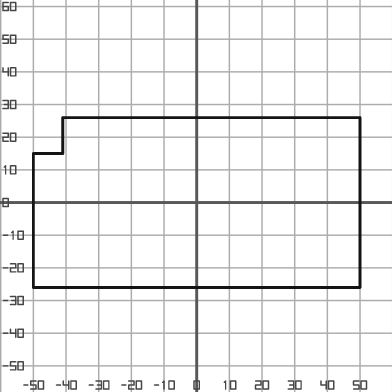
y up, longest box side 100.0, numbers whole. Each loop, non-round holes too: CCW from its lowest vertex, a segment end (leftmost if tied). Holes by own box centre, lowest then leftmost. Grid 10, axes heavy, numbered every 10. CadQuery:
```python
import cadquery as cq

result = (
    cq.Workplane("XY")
    .moveTo(-50.0, -26.0)
    .lineTo(50.0, -26.0)
    .lineTo(50.0, 26.0)
    .lineTo(-41.0, 26.0)
    .lineTo(-41.0, 15.0)
    .lineTo(-50.0, 15.0)
    .close()
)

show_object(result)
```